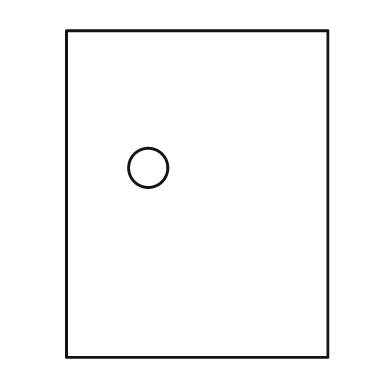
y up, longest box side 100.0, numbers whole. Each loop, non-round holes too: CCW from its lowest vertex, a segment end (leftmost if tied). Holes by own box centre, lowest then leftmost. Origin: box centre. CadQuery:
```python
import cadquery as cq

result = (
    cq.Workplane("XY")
    .moveTo(-40.0, -50.0)
    .lineTo(40.0, -50.0)
    .lineTo(40.0, 50.0)
    .lineTo(-40.0, 50.0)
    .close()
    .moveTo(-15.0, 8.0)
    .circle(6.0)
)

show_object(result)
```